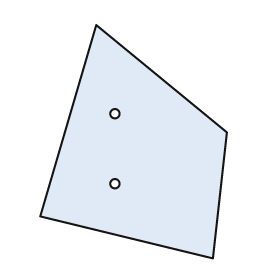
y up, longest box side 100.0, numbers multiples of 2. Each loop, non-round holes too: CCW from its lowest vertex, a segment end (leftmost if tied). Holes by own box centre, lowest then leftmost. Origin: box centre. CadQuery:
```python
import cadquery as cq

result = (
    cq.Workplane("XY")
    .moveTo(34.0, -50.0)
    .lineTo(40.0, 4.0)
    .lineTo(-16.0, 50.0)
    .lineTo(-40.0, -32.0)
    .close()
    .moveTo(-8.0, -18.0)
    .circle(2.0)
    .moveTo(-8.0, 12.0)
    .circle(2.0)
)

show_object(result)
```